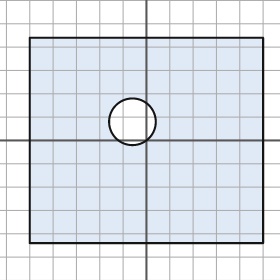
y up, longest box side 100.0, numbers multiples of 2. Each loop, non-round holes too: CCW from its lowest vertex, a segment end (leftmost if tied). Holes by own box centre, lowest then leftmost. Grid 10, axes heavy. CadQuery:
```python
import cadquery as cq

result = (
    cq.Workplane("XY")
    .moveTo(-50.0, -44.0)
    .lineTo(50.0, -44.0)
    .lineTo(50.0, 44.0)
    .lineTo(-50.0, 44.0)
    .close()
    .moveTo(-6.0, 8.0)
    .circle(10.0)
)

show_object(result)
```